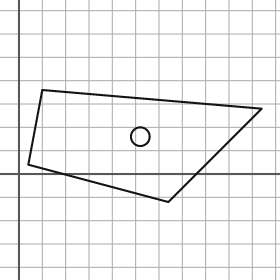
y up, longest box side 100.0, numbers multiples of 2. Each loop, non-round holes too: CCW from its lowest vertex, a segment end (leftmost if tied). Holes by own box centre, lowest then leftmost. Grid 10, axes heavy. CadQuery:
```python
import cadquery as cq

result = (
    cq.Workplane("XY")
    .moveTo(64.0, -12.0)
    .lineTo(104.0, 28.0)
    .lineTo(10.0, 36.0)
    .lineTo(4.0, 4.0)
    .close()
    .moveTo(52.0, 16.0)
    .circle(4.0)
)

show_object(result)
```